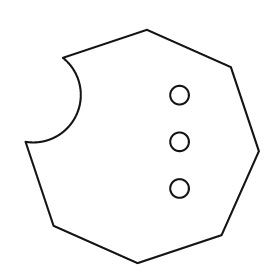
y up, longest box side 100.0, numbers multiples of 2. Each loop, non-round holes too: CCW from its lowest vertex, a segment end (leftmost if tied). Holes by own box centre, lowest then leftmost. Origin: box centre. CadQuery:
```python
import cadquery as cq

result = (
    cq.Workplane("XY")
    .moveTo(-2.0, -50.0)
    .lineTo(34.0, -38.0)
    .lineTo(50.0, -2.0)
    .lineTo(38.0, 34.0)
    .lineTo(2.0, 50.0)
    .lineTo(-34.0, 38.0)
    .threePointArc((-28.0, 14.0), (-50.0, 2.0))
    .lineTo(-38.0, -34.0)
    .close()
    .moveTo(16.0, -18.0)
    .circle(4.0)
    .moveTo(16.0, 2.0)
    .circle(4.0)
    .moveTo(16.0, 22.0)
    .circle(4.0)
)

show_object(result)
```